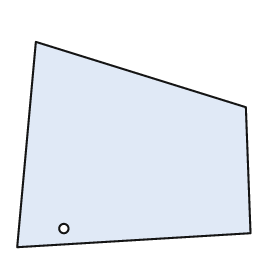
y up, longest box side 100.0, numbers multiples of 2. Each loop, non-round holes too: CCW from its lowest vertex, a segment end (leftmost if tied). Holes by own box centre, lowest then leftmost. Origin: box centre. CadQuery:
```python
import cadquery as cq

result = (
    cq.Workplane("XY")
    .moveTo(-50.0, -44.0)
    .lineTo(50.0, -38.0)
    .lineTo(48.0, 16.0)
    .lineTo(-42.0, 44.0)
    .close()
    .moveTo(-30.0, -36.0)
    .circle(2.0)
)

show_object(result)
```